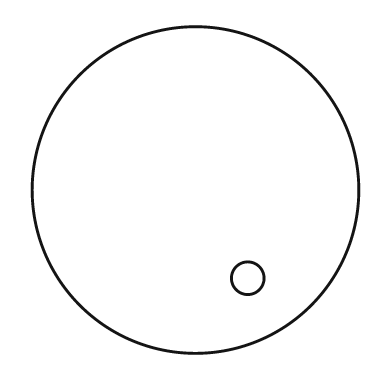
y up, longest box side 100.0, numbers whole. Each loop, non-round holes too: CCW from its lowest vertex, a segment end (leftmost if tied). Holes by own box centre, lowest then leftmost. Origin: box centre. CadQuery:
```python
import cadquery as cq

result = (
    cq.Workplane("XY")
    .moveTo(0.0, 0.0)
    .circle(50.0)
    .moveTo(16.0, -27.0)
    .circle(5.0)
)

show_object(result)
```